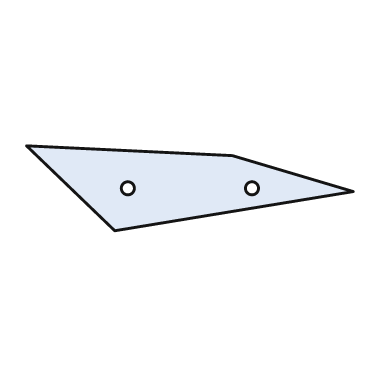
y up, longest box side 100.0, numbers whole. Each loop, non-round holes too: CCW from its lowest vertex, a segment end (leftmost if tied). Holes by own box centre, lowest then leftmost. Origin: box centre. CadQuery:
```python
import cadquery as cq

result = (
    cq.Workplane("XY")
    .moveTo(-23.0, -13.0)
    .lineTo(50.0, -1.0)
    .lineTo(13.0, 10.0)
    .lineTo(-50.0, 13.0)
    .close()
    .moveTo(-19.0, 0.0)
    .circle(2.0)
    .moveTo(19.0, 0.0)
    .circle(2.0)
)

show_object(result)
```